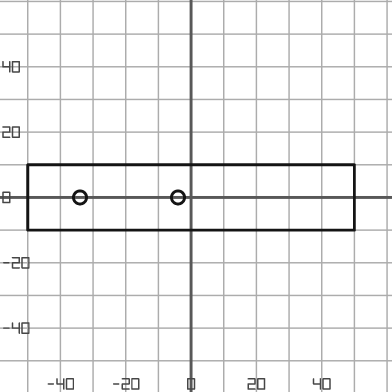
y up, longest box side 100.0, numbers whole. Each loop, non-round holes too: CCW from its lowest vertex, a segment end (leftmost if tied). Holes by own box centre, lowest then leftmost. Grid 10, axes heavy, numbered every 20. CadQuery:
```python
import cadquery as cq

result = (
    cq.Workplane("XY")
    .moveTo(-50.0, -10.0)
    .lineTo(50.0, -10.0)
    .lineTo(50.0, 10.0)
    .lineTo(-50.0, 10.0)
    .close()
    .moveTo(-34.0, 0.0)
    .circle(2.0)
    .moveTo(-4.0, 0.0)
    .circle(2.0)
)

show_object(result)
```